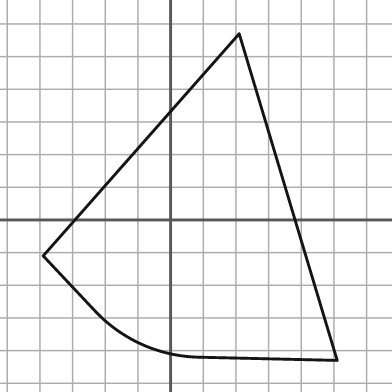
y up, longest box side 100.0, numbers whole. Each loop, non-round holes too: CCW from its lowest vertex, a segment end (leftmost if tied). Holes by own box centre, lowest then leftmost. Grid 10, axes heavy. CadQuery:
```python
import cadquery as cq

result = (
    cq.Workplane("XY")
    .moveTo(51.0, -43.0)
    .lineTo(21.0, 57.0)
    .lineTo(-39.0, -11.0)
    .lineTo(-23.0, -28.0)
    .threePointArc((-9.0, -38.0), (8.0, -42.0))
    .close()
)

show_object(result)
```